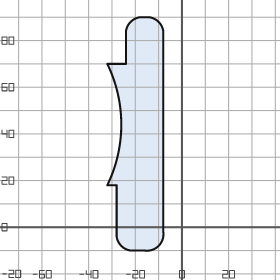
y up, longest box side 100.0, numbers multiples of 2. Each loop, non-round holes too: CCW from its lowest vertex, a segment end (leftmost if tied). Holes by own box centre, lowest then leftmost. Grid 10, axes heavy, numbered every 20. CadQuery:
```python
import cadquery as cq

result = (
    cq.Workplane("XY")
    .moveTo(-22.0, -10.0)
    .lineTo(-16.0, -10.0)
    .threePointArc((-10.0, -8.0), (-8.0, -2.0))
    .lineTo(-8.0, 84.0)
    .threePointArc((-10.0, 88.0), (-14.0, 90.0))
    .lineTo(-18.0, 90.0)
    .threePointArc((-22.0, 88.0), (-24.0, 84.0))
    .lineTo(-24.0, 70.0)
    .lineTo(-32.0, 70.0)
    .threePointArc((-26.0, 44.0), (-32.0, 18.0))
    .lineTo(-28.0, 18.0)
    .lineTo(-28.0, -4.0)
    .threePointArc((-26.0, -8.0), (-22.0, -10.0))
    .close()
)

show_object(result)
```